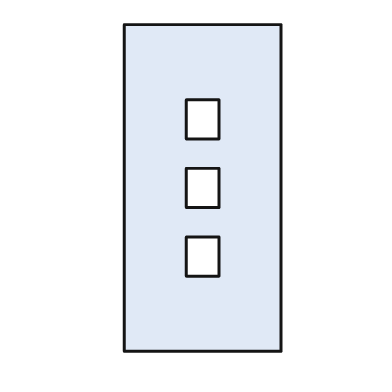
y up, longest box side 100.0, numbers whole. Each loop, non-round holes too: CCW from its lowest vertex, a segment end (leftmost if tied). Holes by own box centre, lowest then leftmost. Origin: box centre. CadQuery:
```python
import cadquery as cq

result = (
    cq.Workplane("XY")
    .moveTo(-24.0, -50.0)
    .lineTo(24.0, -50.0)
    .lineTo(24.0, 50.0)
    .lineTo(-24.0, 50.0)
    .close()
    .moveTo(-5.0, -27.0)
    .lineTo(5.0, -27.0)
    .lineTo(5.0, -15.0)
    .lineTo(-5.0, -15.0)
    .close()
    .moveTo(-5.0, -6.0)
    .lineTo(5.0, -6.0)
    .lineTo(5.0, 6.0)
    .lineTo(-5.0, 6.0)
    .close()
    .moveTo(-5.0, 15.0)
    .lineTo(5.0, 15.0)
    .lineTo(5.0, 27.0)
    .lineTo(-5.0, 27.0)
    .close()
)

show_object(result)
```